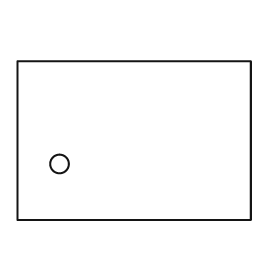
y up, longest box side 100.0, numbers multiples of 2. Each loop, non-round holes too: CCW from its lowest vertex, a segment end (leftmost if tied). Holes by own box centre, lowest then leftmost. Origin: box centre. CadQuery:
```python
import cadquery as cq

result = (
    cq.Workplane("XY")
    .moveTo(-50.0, -34.0)
    .lineTo(50.0, -34.0)
    .lineTo(50.0, 34.0)
    .lineTo(-50.0, 34.0)
    .close()
    .moveTo(-32.0, -10.0)
    .circle(4.0)
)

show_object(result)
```